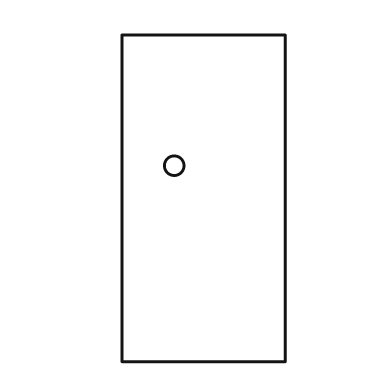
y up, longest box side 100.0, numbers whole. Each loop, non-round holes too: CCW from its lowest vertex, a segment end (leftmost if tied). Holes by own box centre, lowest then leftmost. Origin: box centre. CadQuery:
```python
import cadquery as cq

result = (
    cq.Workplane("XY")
    .moveTo(-25.0, -50.0)
    .lineTo(25.0, -50.0)
    .lineTo(25.0, 50.0)
    .lineTo(-25.0, 50.0)
    .close()
    .moveTo(-9.0, 10.0)
    .circle(3.0)
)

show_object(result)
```